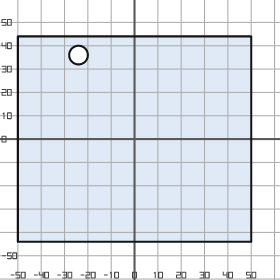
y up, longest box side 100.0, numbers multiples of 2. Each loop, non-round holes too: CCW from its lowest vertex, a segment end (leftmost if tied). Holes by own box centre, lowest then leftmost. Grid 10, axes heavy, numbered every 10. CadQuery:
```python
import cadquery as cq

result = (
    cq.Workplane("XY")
    .moveTo(-50.0, -44.0)
    .lineTo(50.0, -44.0)
    .lineTo(50.0, 44.0)
    .lineTo(-50.0, 44.0)
    .close()
    .moveTo(-24.0, 36.0)
    .circle(4.0)
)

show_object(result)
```